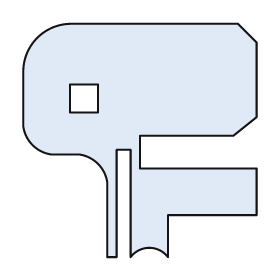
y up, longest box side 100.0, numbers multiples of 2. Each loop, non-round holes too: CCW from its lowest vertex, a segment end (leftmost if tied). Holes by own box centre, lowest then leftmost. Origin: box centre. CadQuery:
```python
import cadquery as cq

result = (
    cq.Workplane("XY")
    .moveTo(-14.0, -50.0)
    .lineTo(-10.0, -50.0)
    .lineTo(-10.0, -4.0)
    .lineTo(-4.0, -4.0)
    .lineTo(-4.0, -50.0)
    .threePointArc((4.0, -46.0), (12.0, -50.0))
    .lineTo(12.0, -32.0)
    .lineTo(50.0, -32.0)
    .lineTo(50.0, -12.0)
    .lineTo(0.0, -12.0)
    .lineTo(0.0, 2.0)
    .lineTo(40.0, 2.0)
    .lineTo(50.0, 10.0)
    .lineTo(50.0, 42.0)
    .lineTo(42.0, 50.0)
    .lineTo(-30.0, 50.0)
    .threePointArc((-44.0, 44.0), (-50.0, 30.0))
    .lineTo(-50.0, 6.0)
    .threePointArc((-46.0, -2.0), (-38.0, -6.0))
    .lineTo(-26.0, -6.0)
    .threePointArc((-18.0, -10.0), (-14.0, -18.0))
    .close()
    .moveTo(-30.0, 12.0)
    .lineTo(-18.0, 12.0)
    .lineTo(-18.0, 24.0)
    .lineTo(-30.0, 24.0)
    .close()
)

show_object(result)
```